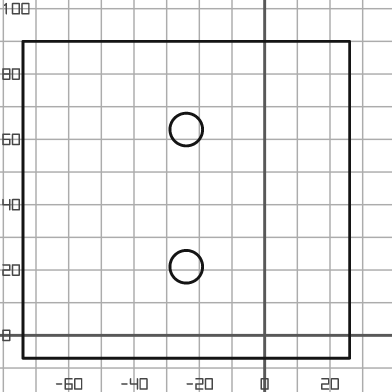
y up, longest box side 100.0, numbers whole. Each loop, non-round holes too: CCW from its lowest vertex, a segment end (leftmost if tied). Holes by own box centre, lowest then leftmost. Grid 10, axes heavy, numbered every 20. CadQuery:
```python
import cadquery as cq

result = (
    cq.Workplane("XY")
    .moveTo(-74.0, -7.0)
    .lineTo(26.0, -7.0)
    .lineTo(26.0, 90.0)
    .lineTo(-74.0, 90.0)
    .close()
    .moveTo(-24.0, 21.0)
    .circle(5.0)
    .moveTo(-24.0, 63.0)
    .circle(5.0)
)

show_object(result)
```